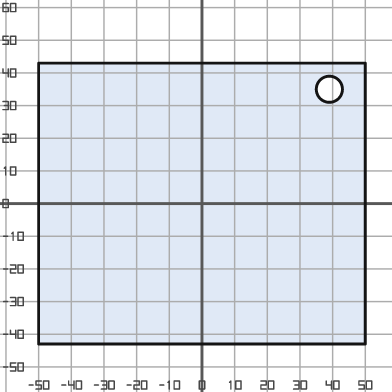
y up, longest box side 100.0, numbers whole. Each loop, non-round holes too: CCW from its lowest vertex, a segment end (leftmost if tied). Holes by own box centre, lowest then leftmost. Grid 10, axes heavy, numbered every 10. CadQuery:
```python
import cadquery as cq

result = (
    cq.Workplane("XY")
    .moveTo(-50.0, -43.0)
    .lineTo(50.0, -43.0)
    .lineTo(50.0, 43.0)
    .lineTo(-50.0, 43.0)
    .close()
    .moveTo(39.0, 35.0)
    .circle(4.0)
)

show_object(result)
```